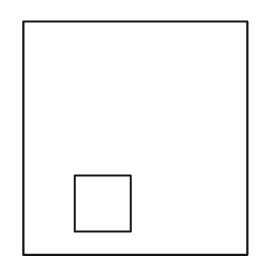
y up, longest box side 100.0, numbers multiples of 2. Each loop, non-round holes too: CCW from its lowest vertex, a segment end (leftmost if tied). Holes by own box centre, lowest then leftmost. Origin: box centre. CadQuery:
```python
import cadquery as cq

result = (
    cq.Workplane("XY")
    .moveTo(-48.0, -50.0)
    .lineTo(48.0, -50.0)
    .lineTo(48.0, 50.0)
    .lineTo(-48.0, 50.0)
    .close()
    .moveTo(-26.0, -40.0)
    .lineTo(-2.0, -40.0)
    .lineTo(-2.0, -16.0)
    .lineTo(-26.0, -16.0)
    .close()
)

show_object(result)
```